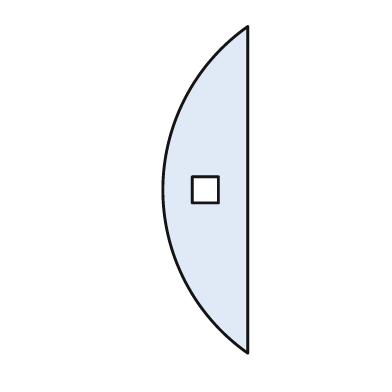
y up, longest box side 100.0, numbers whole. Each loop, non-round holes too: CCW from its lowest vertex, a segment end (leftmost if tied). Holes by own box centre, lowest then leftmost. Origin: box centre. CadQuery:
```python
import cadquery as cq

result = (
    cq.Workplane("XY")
    .moveTo(13.0, -50.0)
    .lineTo(13.0, 50.0)
    .threePointArc((-13.0, 0.0), (13.0, -50.0))
    .close()
    .moveTo(-4.0, -4.0)
    .lineTo(4.0, -4.0)
    .lineTo(4.0, 4.0)
    .lineTo(-4.0, 4.0)
    .close()
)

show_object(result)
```